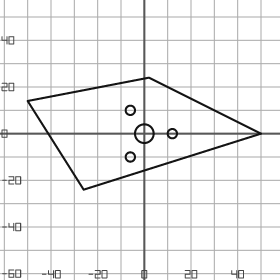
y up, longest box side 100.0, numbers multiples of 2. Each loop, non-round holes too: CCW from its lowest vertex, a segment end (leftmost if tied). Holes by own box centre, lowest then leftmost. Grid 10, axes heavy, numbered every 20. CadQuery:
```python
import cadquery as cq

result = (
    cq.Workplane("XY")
    .moveTo(-26.0, -24.0)
    .lineTo(50.0, 0.0)
    .lineTo(2.0, 24.0)
    .lineTo(-50.0, 14.0)
    .close()
    .moveTo(-6.0, -10.0)
    .circle(2.0)
    .moveTo(0.0, 0.0)
    .circle(4.0)
    .moveTo(12.0, 0.0)
    .circle(2.0)
    .moveTo(-6.0, 10.0)
    .circle(2.0)
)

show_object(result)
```